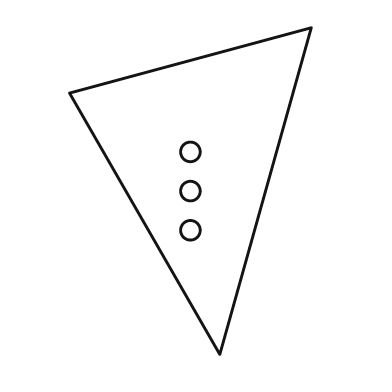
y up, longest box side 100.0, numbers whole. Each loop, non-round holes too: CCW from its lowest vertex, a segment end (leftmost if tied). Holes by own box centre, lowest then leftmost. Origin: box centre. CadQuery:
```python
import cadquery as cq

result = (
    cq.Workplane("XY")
    .moveTo(9.0, -50.0)
    .lineTo(37.0, 50.0)
    .lineTo(-37.0, 30.0)
    .close()
    .moveTo(0.0, -12.0)
    .circle(3.0)
    .moveTo(0.0, 0.0)
    .circle(3.0)
    .moveTo(0.0, 12.0)
    .circle(3.0)
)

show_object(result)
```